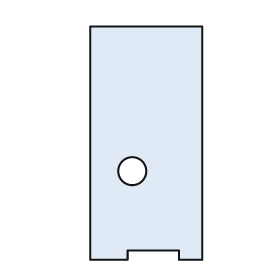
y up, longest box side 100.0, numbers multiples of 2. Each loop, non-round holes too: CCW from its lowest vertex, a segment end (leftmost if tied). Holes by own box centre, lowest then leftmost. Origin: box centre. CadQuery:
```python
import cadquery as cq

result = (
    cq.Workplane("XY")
    .moveTo(-24.0, -50.0)
    .lineTo(-8.0, -50.0)
    .lineTo(-8.0, -46.0)
    .lineTo(14.0, -46.0)
    .lineTo(14.0, -50.0)
    .lineTo(24.0, -50.0)
    .lineTo(24.0, 50.0)
    .lineTo(-24.0, 50.0)
    .close()
    .moveTo(-6.0, -12.0)
    .circle(6.0)
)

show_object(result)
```